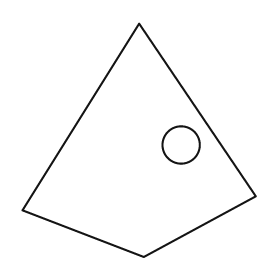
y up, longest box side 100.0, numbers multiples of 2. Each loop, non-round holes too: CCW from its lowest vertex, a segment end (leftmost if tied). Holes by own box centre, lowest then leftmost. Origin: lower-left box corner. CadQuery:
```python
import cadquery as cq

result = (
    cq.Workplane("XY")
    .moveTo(52.0, 0.0)
    .lineTo(100.0, 26.0)
    .lineTo(50.0, 100.0)
    .lineTo(0.0, 20.0)
    .close()
    .moveTo(68.0, 48.0)
    .circle(8.0)
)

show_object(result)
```